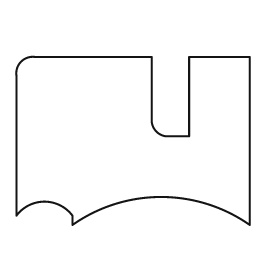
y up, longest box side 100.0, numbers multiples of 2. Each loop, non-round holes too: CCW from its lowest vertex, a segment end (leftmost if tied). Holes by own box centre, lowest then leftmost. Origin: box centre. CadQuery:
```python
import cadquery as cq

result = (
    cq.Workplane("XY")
    .moveTo(-26.0, -36.0)
    .threePointArc((12.0, -24.0), (50.0, -36.0))
    .lineTo(50.0, 36.0)
    .lineTo(24.0, 36.0)
    .lineTo(24.0, 2.0)
    .lineTo(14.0, 2.0)
    .threePointArc((10.0, 4.0), (8.0, 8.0))
    .lineTo(8.0, 36.0)
    .lineTo(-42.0, 36.0)
    .threePointArc((-48.0, 34.0), (-50.0, 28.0))
    .lineTo(-50.0, -32.0)
    .threePointArc((-38.0, -26.0), (-26.0, -32.0))
    .close()
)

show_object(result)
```